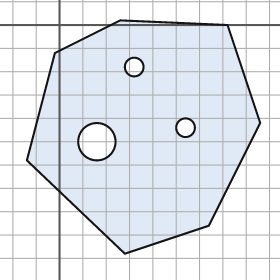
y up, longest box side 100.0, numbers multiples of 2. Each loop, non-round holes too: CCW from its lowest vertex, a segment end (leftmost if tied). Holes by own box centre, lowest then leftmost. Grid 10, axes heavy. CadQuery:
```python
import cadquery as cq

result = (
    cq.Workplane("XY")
    .moveTo(28.0, -98.0)
    .lineTo(64.0, -86.0)
    .lineTo(86.0, -42.0)
    .lineTo(72.0, 0.0)
    .lineTo(26.0, 2.0)
    .lineTo(-2.0, -12.0)
    .lineTo(-14.0, -58.0)
    .close()
    .moveTo(16.0, -50.0)
    .circle(8.0)
    .moveTo(54.0, -44.0)
    .circle(4.0)
    .moveTo(32.0, -18.0)
    .circle(4.0)
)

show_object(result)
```